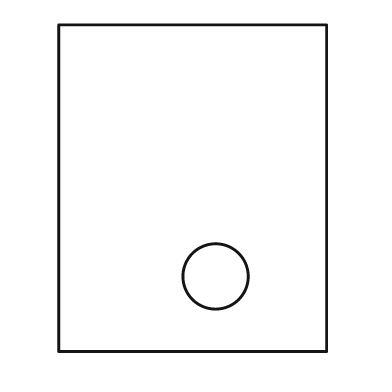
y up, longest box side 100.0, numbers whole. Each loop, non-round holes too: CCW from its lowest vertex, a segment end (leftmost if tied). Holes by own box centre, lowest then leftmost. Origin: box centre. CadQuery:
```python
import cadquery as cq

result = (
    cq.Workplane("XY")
    .moveTo(-41.0, -50.0)
    .lineTo(41.0, -50.0)
    .lineTo(41.0, 50.0)
    .lineTo(-41.0, 50.0)
    .close()
    .moveTo(7.0, -27.0)
    .circle(10.0)
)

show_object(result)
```